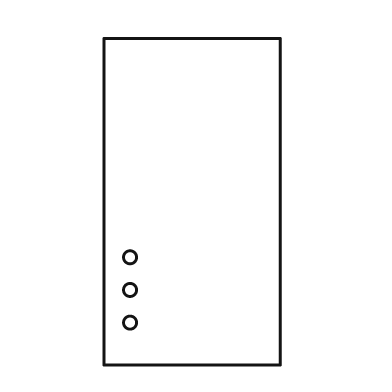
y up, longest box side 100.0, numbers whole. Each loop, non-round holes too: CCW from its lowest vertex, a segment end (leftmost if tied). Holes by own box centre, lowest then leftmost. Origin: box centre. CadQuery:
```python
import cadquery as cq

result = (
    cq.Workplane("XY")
    .moveTo(-27.0, -50.0)
    .lineTo(27.0, -50.0)
    .lineTo(27.0, 50.0)
    .lineTo(-27.0, 50.0)
    .close()
    .moveTo(-19.0, -37.0)
    .circle(2.0)
    .moveTo(-19.0, -27.0)
    .circle(2.0)
    .moveTo(-19.0, -17.0)
    .circle(2.0)
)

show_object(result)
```